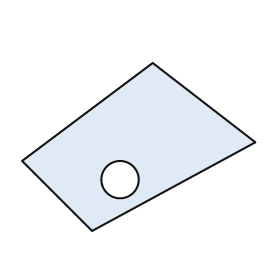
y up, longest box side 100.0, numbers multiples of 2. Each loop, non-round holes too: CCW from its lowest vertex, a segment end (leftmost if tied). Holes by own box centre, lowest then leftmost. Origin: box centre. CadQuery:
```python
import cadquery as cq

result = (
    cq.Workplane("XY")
    .moveTo(-20.0, -36.0)
    .lineTo(50.0, 2.0)
    .lineTo(6.0, 36.0)
    .lineTo(-50.0, -6.0)
    .close()
    .moveTo(-8.0, -14.0)
    .circle(8.0)
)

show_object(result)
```